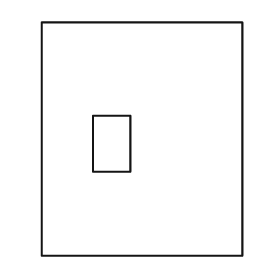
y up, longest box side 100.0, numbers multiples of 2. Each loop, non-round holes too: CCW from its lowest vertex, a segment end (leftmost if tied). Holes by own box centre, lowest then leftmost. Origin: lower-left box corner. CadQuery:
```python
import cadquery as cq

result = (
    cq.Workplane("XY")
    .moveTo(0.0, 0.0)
    .lineTo(86.0, 0.0)
    .lineTo(86.0, 100.0)
    .lineTo(0.0, 100.0)
    .close()
    .moveTo(22.0, 36.0)
    .lineTo(38.0, 36.0)
    .lineTo(38.0, 60.0)
    .lineTo(22.0, 60.0)
    .close()
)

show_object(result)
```